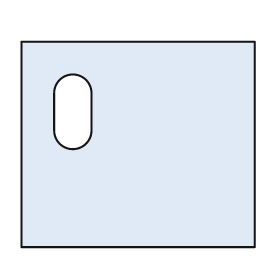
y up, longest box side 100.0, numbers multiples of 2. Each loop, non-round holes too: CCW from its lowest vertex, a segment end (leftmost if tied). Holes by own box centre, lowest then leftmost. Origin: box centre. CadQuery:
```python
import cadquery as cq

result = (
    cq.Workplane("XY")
    .moveTo(-50.0, -44.0)
    .lineTo(50.0, -44.0)
    .lineTo(50.0, 44.0)
    .lineTo(-50.0, 44.0)
    .close()
    .moveTo(-36.0, 6.0)
    .threePointArc((-28.0, -2.0), (-20.0, 6.0))
    .lineTo(-20.0, 22.0)
    .threePointArc((-28.0, 30.0), (-36.0, 22.0))
    .close()
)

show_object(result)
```